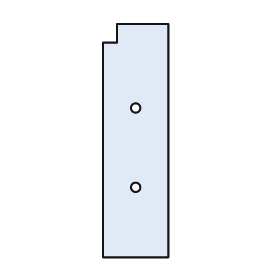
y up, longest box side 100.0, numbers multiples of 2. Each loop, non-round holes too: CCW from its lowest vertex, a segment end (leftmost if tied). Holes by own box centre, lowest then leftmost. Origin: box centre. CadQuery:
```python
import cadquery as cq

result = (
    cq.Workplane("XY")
    .moveTo(-14.0, -50.0)
    .lineTo(14.0, -50.0)
    .lineTo(14.0, 50.0)
    .lineTo(-8.0, 50.0)
    .lineTo(-8.0, 42.0)
    .lineTo(-14.0, 42.0)
    .close()
    .moveTo(0.0, -20.0)
    .circle(2.0)
    .moveTo(0.0, 14.0)
    .circle(2.0)
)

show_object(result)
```